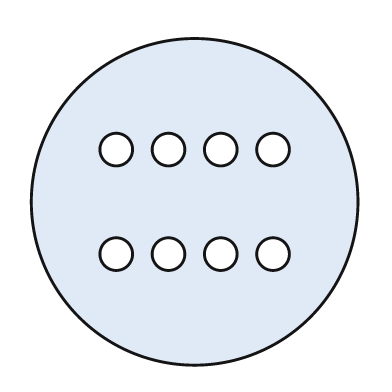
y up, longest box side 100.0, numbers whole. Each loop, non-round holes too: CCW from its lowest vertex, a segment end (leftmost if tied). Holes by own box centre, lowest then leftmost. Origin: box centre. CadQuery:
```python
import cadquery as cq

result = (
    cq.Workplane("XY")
    .moveTo(0.0, 0.0)
    .circle(50.0)
    .moveTo(-24.0, -16.0)
    .circle(5.0)
    .moveTo(-8.0, -16.0)
    .circle(5.0)
    .moveTo(8.0, -16.0)
    .circle(5.0)
    .moveTo(24.0, -16.0)
    .circle(5.0)
    .moveTo(-24.0, 16.0)
    .circle(5.0)
    .moveTo(-8.0, 16.0)
    .circle(5.0)
    .moveTo(8.0, 16.0)
    .circle(5.0)
    .moveTo(24.0, 16.0)
    .circle(5.0)
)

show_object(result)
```